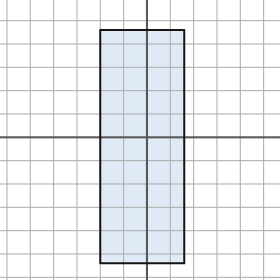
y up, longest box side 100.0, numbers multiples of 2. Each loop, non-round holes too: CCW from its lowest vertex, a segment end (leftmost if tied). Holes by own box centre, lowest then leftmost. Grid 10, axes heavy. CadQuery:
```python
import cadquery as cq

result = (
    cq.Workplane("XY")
    .moveTo(-20.0, -54.0)
    .lineTo(16.0, -54.0)
    .lineTo(16.0, 46.0)
    .lineTo(-20.0, 46.0)
    .close()
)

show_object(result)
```